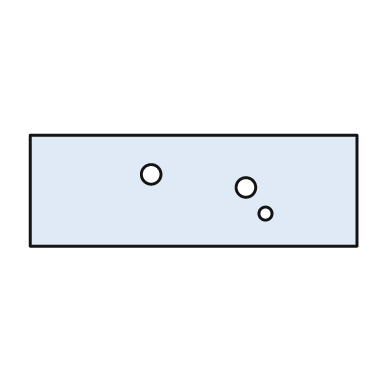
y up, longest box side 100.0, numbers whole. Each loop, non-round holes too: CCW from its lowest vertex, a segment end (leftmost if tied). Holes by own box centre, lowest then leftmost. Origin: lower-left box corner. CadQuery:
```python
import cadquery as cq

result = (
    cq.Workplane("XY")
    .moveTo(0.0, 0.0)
    .lineTo(100.0, 0.0)
    .lineTo(100.0, 34.0)
    .lineTo(0.0, 34.0)
    .close()
    .moveTo(72.0, 10.0)
    .circle(2.0)
    .moveTo(66.0, 18.0)
    .circle(3.0)
    .moveTo(37.0, 22.0)
    .circle(3.0)
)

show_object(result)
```